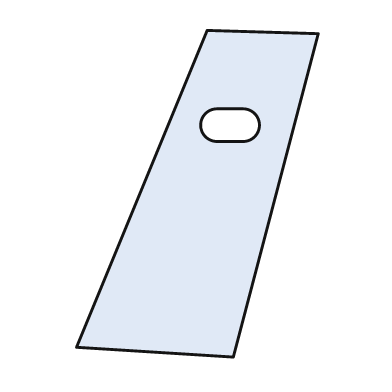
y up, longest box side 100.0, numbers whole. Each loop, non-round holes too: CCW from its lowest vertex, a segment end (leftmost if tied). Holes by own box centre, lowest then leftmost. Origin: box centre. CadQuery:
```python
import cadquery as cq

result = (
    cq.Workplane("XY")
    .moveTo(11.0, -50.0)
    .lineTo(37.0, 49.0)
    .lineTo(3.0, 50.0)
    .lineTo(-37.0, -47.0)
    .close()
    .moveTo(6.0, 16.0)
    .lineTo(14.0, 16.0)
    .threePointArc((19.0, 21.0), (14.0, 26.0))
    .lineTo(6.0, 26.0)
    .threePointArc((1.0, 21.0), (6.0, 16.0))
    .close()
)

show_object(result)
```